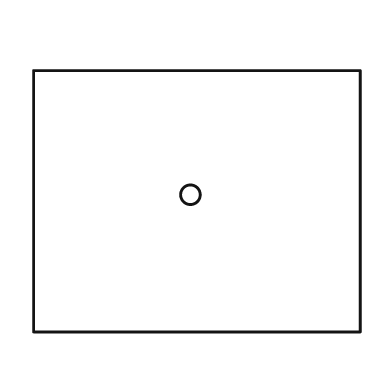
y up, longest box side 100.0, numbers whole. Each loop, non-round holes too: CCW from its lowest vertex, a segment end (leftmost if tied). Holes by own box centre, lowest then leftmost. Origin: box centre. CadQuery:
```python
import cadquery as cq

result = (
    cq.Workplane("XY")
    .moveTo(-50.0, -40.0)
    .lineTo(50.0, -40.0)
    .lineTo(50.0, 40.0)
    .lineTo(-50.0, 40.0)
    .close()
    .moveTo(-2.0, 2.0)
    .circle(3.0)
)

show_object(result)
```